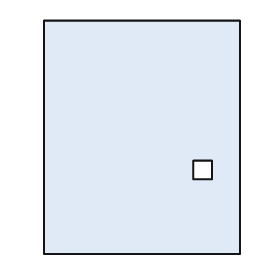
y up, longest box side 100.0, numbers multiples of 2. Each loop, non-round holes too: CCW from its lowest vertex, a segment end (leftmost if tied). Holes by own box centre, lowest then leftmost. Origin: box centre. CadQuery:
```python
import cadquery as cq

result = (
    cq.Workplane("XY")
    .moveTo(-42.0, -50.0)
    .lineTo(42.0, -50.0)
    .lineTo(42.0, 50.0)
    .lineTo(-42.0, 50.0)
    .close()
    .moveTo(22.0, -18.0)
    .lineTo(30.0, -18.0)
    .lineTo(30.0, -10.0)
    .lineTo(22.0, -10.0)
    .close()
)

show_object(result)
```